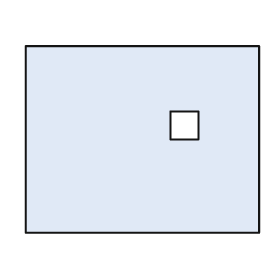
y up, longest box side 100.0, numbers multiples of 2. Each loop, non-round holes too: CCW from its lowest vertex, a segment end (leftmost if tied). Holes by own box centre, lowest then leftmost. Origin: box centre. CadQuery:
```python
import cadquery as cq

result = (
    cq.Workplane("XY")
    .moveTo(-50.0, -40.0)
    .lineTo(50.0, -40.0)
    .lineTo(50.0, 40.0)
    .lineTo(-50.0, 40.0)
    .close()
    .moveTo(12.0, 0.0)
    .lineTo(24.0, 0.0)
    .lineTo(24.0, 12.0)
    .lineTo(12.0, 12.0)
    .close()
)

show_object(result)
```